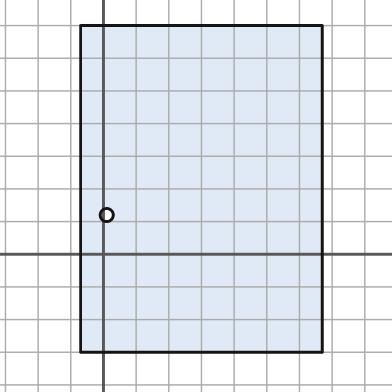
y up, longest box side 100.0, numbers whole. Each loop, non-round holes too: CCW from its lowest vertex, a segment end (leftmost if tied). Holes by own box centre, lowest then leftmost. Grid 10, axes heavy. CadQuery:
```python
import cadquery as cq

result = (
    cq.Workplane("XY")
    .moveTo(-7.0, -30.0)
    .lineTo(67.0, -30.0)
    .lineTo(67.0, 70.0)
    .lineTo(-7.0, 70.0)
    .close()
    .moveTo(1.0, 12.0)
    .circle(2.0)
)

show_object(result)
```